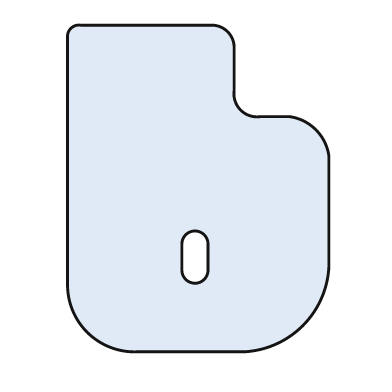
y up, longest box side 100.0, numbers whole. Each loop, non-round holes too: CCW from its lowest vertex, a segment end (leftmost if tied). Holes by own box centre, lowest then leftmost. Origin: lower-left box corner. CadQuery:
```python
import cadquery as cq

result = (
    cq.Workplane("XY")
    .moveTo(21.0, 0.0)
    .lineTo(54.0, 0.0)
    .threePointArc((72.0, 8.0), (80.0, 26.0))
    .lineTo(80.0, 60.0)
    .threePointArc((76.0, 68.0), (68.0, 72.0))
    .lineTo(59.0, 72.0)
    .threePointArc((53.0, 74.0), (51.0, 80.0))
    .lineTo(51.0, 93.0)
    .threePointArc((49.0, 98.0), (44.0, 100.0))
    .lineTo(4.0, 100.0)
    .threePointArc((1.0, 99.0), (0.0, 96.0))
    .lineTo(0.0, 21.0)
    .threePointArc((6.0, 6.0), (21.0, 0.0))
    .close()
    .moveTo(35.0, 25.0)
    .threePointArc((39.0, 21.0), (43.0, 25.0))
    .lineTo(43.0, 33.0)
    .threePointArc((39.0, 37.0), (35.0, 33.0))
    .close()
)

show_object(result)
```